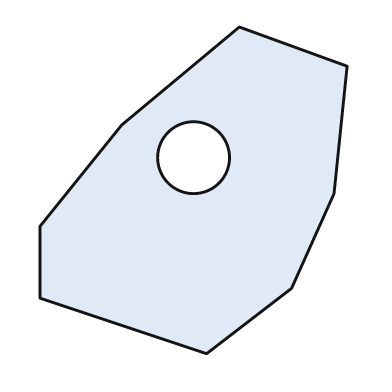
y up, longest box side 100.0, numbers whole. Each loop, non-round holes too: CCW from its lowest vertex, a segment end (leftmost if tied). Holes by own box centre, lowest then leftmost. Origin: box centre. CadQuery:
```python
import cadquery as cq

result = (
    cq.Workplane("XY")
    .moveTo(4.0, -50.0)
    .lineTo(30.0, -30.0)
    .lineTo(43.0, -1.0)
    .lineTo(47.0, 38.0)
    .lineTo(14.0, 50.0)
    .lineTo(-22.0, 20.0)
    .lineTo(-47.0, -11.0)
    .lineTo(-47.0, -33.0)
    .close()
    .moveTo(0.0, 10.0)
    .circle(11.0)
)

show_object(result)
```